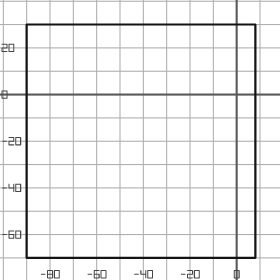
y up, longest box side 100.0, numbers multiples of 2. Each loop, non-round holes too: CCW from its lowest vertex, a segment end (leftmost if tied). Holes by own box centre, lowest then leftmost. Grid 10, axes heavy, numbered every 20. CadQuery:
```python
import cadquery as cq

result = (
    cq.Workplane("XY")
    .moveTo(-90.0, -70.0)
    .lineTo(8.0, -70.0)
    .lineTo(8.0, 30.0)
    .lineTo(-90.0, 30.0)
    .close()
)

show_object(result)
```